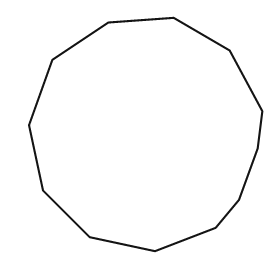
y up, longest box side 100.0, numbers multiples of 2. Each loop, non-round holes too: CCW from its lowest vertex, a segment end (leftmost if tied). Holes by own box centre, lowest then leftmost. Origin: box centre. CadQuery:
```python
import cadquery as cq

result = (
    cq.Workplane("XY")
    .moveTo(4.0, -50.0)
    .lineTo(30.0, -40.0)
    .lineTo(40.0, -28.0)
    .lineTo(48.0, -6.0)
    .lineTo(50.0, 10.0)
    .lineTo(36.0, 36.0)
    .lineTo(12.0, 50.0)
    .lineTo(-16.0, 48.0)
    .lineTo(-40.0, 32.0)
    .lineTo(-50.0, 4.0)
    .lineTo(-44.0, -24.0)
    .lineTo(-24.0, -44.0)
    .close()
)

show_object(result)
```